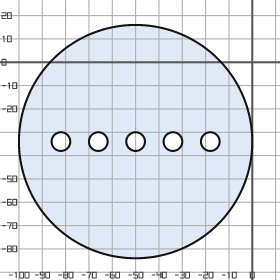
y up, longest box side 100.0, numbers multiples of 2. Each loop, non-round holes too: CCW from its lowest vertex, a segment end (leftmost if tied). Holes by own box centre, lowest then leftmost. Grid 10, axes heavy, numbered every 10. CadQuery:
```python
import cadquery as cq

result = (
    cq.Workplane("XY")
    .moveTo(-50.0, -34.0)
    .circle(50.0)
    .moveTo(-82.0, -34.0)
    .circle(4.0)
    .moveTo(-66.0, -34.0)
    .circle(4.0)
    .moveTo(-50.0, -34.0)
    .circle(4.0)
    .moveTo(-34.0, -34.0)
    .circle(4.0)
    .moveTo(-18.0, -34.0)
    .circle(4.0)
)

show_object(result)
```